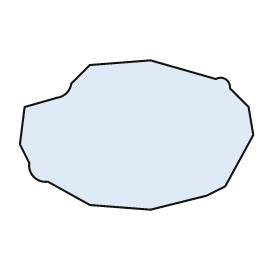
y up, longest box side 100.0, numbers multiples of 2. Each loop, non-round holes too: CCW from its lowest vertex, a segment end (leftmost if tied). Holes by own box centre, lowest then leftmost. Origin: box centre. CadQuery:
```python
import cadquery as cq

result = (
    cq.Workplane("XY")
    .moveTo(6.0, -32.0)
    .lineTo(30.0, -26.0)
    .lineTo(38.0, -22.0)
    .lineTo(50.0, 0.0)
    .lineTo(48.0, 12.0)
    .lineTo(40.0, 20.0)
    .threePointArc((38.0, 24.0), (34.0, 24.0))
    .lineTo(6.0, 32.0)
    .lineTo(-20.0, 30.0)
    .lineTo(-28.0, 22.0)
    .threePointArc((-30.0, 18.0), (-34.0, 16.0))
    .lineTo(-48.0, 12.0)
    .lineTo(-50.0, -4.0)
    .lineTo(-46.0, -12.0)
    .threePointArc((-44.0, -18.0), (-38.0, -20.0))
    .lineTo(-20.0, -30.0)
    .close()
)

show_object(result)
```